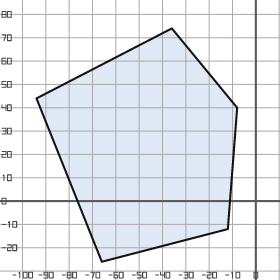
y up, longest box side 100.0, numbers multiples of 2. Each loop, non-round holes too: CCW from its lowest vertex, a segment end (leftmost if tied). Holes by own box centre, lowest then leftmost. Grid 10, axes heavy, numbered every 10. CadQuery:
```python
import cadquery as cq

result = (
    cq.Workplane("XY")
    .moveTo(-66.0, -26.0)
    .lineTo(-12.0, -12.0)
    .lineTo(-8.0, 40.0)
    .lineTo(-36.0, 74.0)
    .lineTo(-94.0, 44.0)
    .close()
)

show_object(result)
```